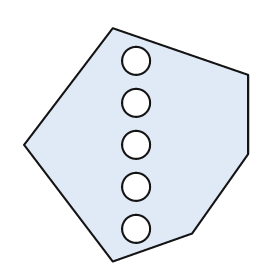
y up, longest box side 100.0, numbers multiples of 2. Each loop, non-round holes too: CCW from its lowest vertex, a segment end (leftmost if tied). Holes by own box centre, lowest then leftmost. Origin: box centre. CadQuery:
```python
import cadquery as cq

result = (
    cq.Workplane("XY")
    .moveTo(-10.0, -50.0)
    .lineTo(24.0, -38.0)
    .lineTo(48.0, -4.0)
    .lineTo(48.0, 30.0)
    .lineTo(-10.0, 50.0)
    .lineTo(-48.0, 0.0)
    .close()
    .moveTo(0.0, -36.0)
    .circle(6.0)
    .moveTo(0.0, -18.0)
    .circle(6.0)
    .moveTo(0.0, 0.0)
    .circle(6.0)
    .moveTo(0.0, 18.0)
    .circle(6.0)
    .moveTo(0.0, 36.0)
    .circle(6.0)
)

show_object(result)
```